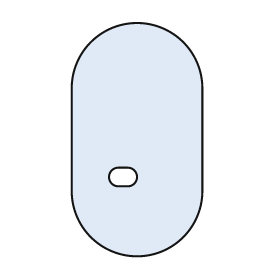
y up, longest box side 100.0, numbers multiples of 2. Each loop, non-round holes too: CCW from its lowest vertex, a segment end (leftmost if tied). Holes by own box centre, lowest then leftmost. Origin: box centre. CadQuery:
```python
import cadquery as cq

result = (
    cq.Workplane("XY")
    .moveTo(-28.0, -22.0)
    .threePointArc((0.0, -50.0), (28.0, -22.0))
    .lineTo(28.0, 22.0)
    .threePointArc((0.0, 50.0), (-28.0, 22.0))
    .close()
    .moveTo(-8.0, -20.0)
    .lineTo(-4.0, -20.0)
    .threePointArc((0.0, -16.0), (-4.0, -12.0))
    .lineTo(-8.0, -12.0)
    .threePointArc((-12.0, -16.0), (-8.0, -20.0))
    .close()
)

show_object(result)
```